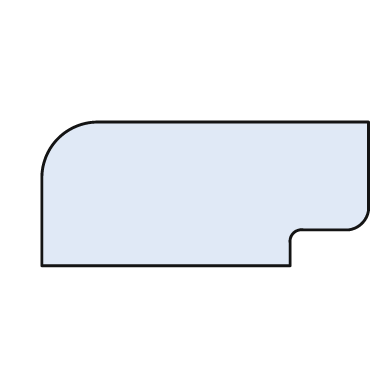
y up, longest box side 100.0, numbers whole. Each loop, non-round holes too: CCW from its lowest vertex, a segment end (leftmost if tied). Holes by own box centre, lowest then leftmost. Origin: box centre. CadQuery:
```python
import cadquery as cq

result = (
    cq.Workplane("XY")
    .moveTo(-50.0, -22.0)
    .lineTo(26.0, -22.0)
    .lineTo(26.0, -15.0)
    .threePointArc((27.0, -12.0), (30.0, -11.0))
    .lineTo(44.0, -11.0)
    .threePointArc((48.0, -9.0), (50.0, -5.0))
    .lineTo(50.0, 22.0)
    .lineTo(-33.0, 22.0)
    .threePointArc((-45.0, 17.0), (-50.0, 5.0))
    .close()
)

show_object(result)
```